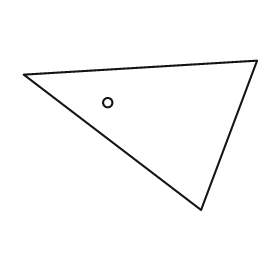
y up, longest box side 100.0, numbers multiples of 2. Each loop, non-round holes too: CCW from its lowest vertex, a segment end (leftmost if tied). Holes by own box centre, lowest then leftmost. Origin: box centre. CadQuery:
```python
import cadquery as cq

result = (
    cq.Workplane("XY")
    .moveTo(26.0, -32.0)
    .lineTo(50.0, 32.0)
    .lineTo(-50.0, 26.0)
    .close()
    .moveTo(-14.0, 14.0)
    .circle(2.0)
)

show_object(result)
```